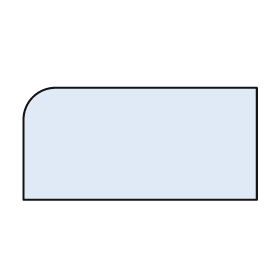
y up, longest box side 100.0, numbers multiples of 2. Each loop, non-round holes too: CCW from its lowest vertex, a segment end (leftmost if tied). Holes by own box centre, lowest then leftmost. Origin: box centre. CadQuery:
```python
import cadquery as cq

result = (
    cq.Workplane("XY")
    .moveTo(-50.0, -24.0)
    .lineTo(50.0, -24.0)
    .lineTo(50.0, 24.0)
    .lineTo(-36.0, 24.0)
    .threePointArc((-46.0, 20.0), (-50.0, 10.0))
    .close()
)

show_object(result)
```